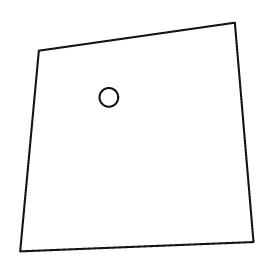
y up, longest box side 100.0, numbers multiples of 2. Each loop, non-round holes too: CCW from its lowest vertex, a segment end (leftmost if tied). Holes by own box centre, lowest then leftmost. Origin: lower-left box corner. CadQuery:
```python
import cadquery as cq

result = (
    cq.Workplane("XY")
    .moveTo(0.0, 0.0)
    .lineTo(100.0, 4.0)
    .lineTo(92.0, 98.0)
    .lineTo(8.0, 86.0)
    .close()
    .moveTo(38.0, 66.0)
    .circle(4.0)
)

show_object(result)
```